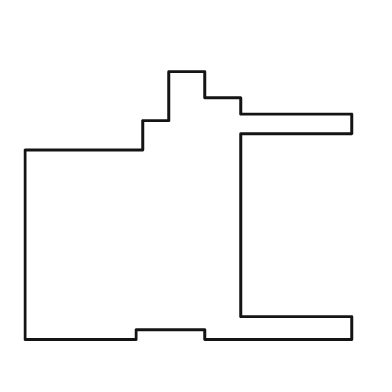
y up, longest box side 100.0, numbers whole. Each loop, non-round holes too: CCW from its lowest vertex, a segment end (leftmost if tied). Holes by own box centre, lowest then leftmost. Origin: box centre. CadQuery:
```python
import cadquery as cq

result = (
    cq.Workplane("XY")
    .moveTo(-50.0, -41.0)
    .lineTo(-16.0, -41.0)
    .lineTo(-16.0, -38.0)
    .lineTo(5.0, -38.0)
    .lineTo(5.0, -41.0)
    .lineTo(50.0, -41.0)
    .lineTo(50.0, -34.0)
    .lineTo(16.0, -34.0)
    .lineTo(16.0, 22.0)
    .lineTo(50.0, 22.0)
    .lineTo(50.0, 28.0)
    .lineTo(16.0, 28.0)
    .lineTo(16.0, 33.0)
    .lineTo(5.0, 33.0)
    .lineTo(5.0, 41.0)
    .lineTo(-6.0, 41.0)
    .lineTo(-6.0, 26.0)
    .lineTo(-14.0, 26.0)
    .lineTo(-14.0, 17.0)
    .lineTo(-50.0, 17.0)
    .close()
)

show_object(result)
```